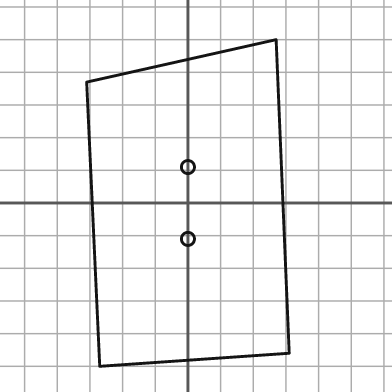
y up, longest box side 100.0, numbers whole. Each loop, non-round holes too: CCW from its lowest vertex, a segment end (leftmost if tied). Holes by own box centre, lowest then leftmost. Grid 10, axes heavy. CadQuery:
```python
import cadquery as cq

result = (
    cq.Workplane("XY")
    .moveTo(-27.0, -50.0)
    .lineTo(31.0, -46.0)
    .lineTo(27.0, 50.0)
    .lineTo(-31.0, 37.0)
    .close()
    .moveTo(0.0, -11.0)
    .circle(2.0)
    .moveTo(0.0, 11.0)
    .circle(2.0)
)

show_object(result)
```